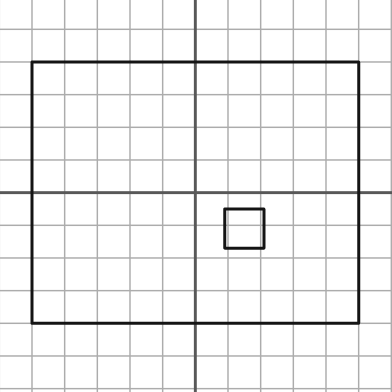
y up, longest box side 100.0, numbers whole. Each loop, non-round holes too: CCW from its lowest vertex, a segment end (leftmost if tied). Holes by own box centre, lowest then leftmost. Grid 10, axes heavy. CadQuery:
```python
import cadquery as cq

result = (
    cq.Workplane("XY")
    .moveTo(-50.0, -40.0)
    .lineTo(50.0, -40.0)
    .lineTo(50.0, 40.0)
    .lineTo(-50.0, 40.0)
    .close()
    .moveTo(9.0, -17.0)
    .lineTo(21.0, -17.0)
    .lineTo(21.0, -5.0)
    .lineTo(9.0, -5.0)
    .close()
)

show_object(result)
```